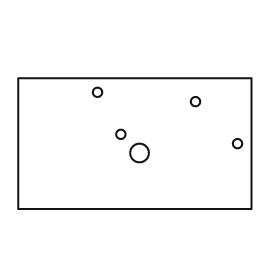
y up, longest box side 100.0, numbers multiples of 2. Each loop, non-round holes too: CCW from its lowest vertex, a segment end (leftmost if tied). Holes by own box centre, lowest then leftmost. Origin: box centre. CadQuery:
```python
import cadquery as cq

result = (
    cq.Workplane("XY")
    .moveTo(-50.0, -28.0)
    .lineTo(50.0, -28.0)
    .lineTo(50.0, 28.0)
    .lineTo(-50.0, 28.0)
    .close()
    .moveTo(2.0, -4.0)
    .circle(4.0)
    .moveTo(44.0, 0.0)
    .circle(2.0)
    .moveTo(-6.0, 4.0)
    .circle(2.0)
    .moveTo(26.0, 18.0)
    .circle(2.0)
    .moveTo(-16.0, 22.0)
    .circle(2.0)
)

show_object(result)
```